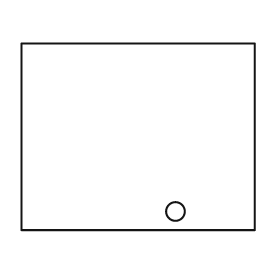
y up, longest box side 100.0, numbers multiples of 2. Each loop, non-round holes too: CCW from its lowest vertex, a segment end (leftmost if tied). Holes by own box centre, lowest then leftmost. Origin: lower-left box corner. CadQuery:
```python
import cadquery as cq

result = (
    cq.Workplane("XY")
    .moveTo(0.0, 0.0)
    .lineTo(100.0, 0.0)
    .lineTo(100.0, 80.0)
    .lineTo(0.0, 80.0)
    .close()
    .moveTo(66.0, 8.0)
    .circle(4.0)
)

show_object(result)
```